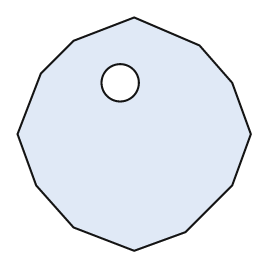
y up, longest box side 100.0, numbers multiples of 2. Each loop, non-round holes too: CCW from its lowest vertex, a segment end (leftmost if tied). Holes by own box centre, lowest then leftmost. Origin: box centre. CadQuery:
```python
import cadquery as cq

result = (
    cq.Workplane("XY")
    .moveTo(0.0, -50.0)
    .lineTo(22.0, -42.0)
    .lineTo(42.0, -22.0)
    .lineTo(50.0, 0.0)
    .lineTo(42.0, 22.0)
    .lineTo(28.0, 38.0)
    .lineTo(0.0, 50.0)
    .lineTo(-26.0, 40.0)
    .lineTo(-40.0, 26.0)
    .lineTo(-50.0, 0.0)
    .lineTo(-42.0, -22.0)
    .lineTo(-26.0, -40.0)
    .close()
    .moveTo(-6.0, 22.0)
    .circle(8.0)
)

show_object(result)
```